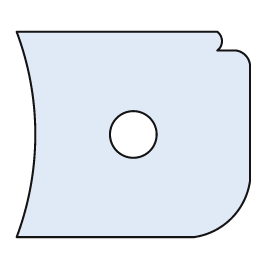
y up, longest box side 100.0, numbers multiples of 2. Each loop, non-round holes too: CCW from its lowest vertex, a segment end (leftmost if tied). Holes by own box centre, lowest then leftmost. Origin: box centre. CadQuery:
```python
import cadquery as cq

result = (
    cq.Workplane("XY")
    .moveTo(-50.0, -44.0)
    .lineTo(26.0, -44.0)
    .threePointArc((42.0, -36.0), (50.0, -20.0))
    .lineTo(50.0, 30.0)
    .threePointArc((48.0, 34.0), (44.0, 36.0))
    .lineTo(36.0, 36.0)
    .threePointArc((38.0, 40.0), (36.0, 44.0))
    .lineTo(-50.0, 44.0)
    .threePointArc((-42.0, 0.0), (-50.0, -44.0))
    .close()
    .moveTo(0.0, 0.0)
    .circle(10.0)
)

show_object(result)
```